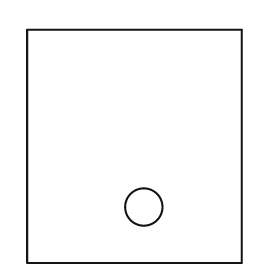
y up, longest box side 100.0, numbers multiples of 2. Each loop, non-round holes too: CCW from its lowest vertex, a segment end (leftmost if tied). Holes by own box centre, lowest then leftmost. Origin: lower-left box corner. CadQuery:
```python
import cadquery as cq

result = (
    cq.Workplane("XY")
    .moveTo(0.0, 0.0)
    .lineTo(92.0, 0.0)
    .lineTo(92.0, 100.0)
    .lineTo(0.0, 100.0)
    .close()
    .moveTo(50.0, 24.0)
    .circle(8.0)
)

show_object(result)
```